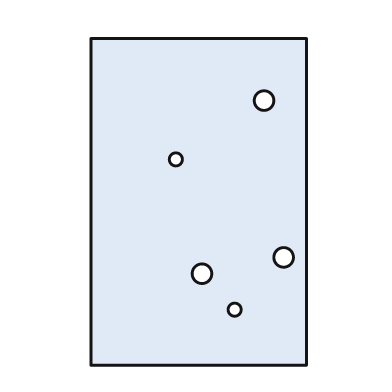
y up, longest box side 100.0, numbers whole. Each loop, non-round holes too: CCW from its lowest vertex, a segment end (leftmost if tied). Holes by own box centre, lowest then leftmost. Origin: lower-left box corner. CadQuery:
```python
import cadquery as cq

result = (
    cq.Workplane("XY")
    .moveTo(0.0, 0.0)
    .lineTo(66.0, 0.0)
    .lineTo(66.0, 100.0)
    .lineTo(0.0, 100.0)
    .close()
    .moveTo(44.0, 17.0)
    .circle(2.0)
    .moveTo(34.0, 28.0)
    .circle(3.0)
    .moveTo(59.0, 33.0)
    .circle(3.0)
    .moveTo(26.0, 63.0)
    .circle(2.0)
    .moveTo(53.0, 81.0)
    .circle(3.0)
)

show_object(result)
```